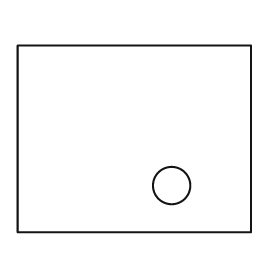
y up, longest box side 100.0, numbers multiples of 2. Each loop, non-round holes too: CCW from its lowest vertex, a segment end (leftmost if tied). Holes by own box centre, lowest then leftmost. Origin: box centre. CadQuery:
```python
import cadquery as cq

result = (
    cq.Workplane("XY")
    .moveTo(-50.0, -40.0)
    .lineTo(50.0, -40.0)
    .lineTo(50.0, 40.0)
    .lineTo(-50.0, 40.0)
    .close()
    .moveTo(16.0, -20.0)
    .circle(8.0)
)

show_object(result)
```